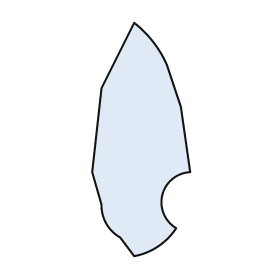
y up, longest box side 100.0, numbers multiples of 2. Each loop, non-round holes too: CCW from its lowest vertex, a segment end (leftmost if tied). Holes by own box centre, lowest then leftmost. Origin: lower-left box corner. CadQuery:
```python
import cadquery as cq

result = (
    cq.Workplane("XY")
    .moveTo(18.0, 0.0)
    .threePointArc((28.0, 4.0), (36.0, 12.0))
    .threePointArc((30.0, 26.0), (42.0, 36.0))
    .lineTo(38.0, 64.0)
    .lineTo(32.0, 82.0)
    .threePointArc((26.0, 92.0), (18.0, 100.0))
    .lineTo(4.0, 72.0)
    .lineTo(0.0, 36.0)
    .lineTo(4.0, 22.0)
    .threePointArc((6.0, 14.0), (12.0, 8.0))
    .close()
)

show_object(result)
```